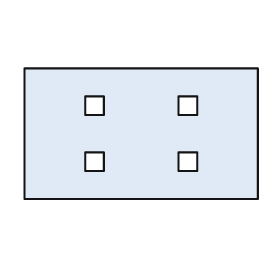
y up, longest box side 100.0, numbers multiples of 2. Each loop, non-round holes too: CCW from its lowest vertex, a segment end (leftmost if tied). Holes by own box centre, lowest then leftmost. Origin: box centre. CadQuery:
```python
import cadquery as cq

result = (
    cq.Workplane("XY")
    .moveTo(-50.0, -28.0)
    .lineTo(50.0, -28.0)
    .lineTo(50.0, 28.0)
    .lineTo(-50.0, 28.0)
    .close()
    .moveTo(-24.0, -16.0)
    .lineTo(-16.0, -16.0)
    .lineTo(-16.0, -8.0)
    .lineTo(-24.0, -8.0)
    .close()
    .moveTo(16.0, -16.0)
    .lineTo(24.0, -16.0)
    .lineTo(24.0, -8.0)
    .lineTo(16.0, -8.0)
    .close()
    .moveTo(-24.0, 8.0)
    .lineTo(-16.0, 8.0)
    .lineTo(-16.0, 16.0)
    .lineTo(-24.0, 16.0)
    .close()
    .moveTo(16.0, 8.0)
    .lineTo(24.0, 8.0)
    .lineTo(24.0, 16.0)
    .lineTo(16.0, 16.0)
    .close()
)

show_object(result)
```